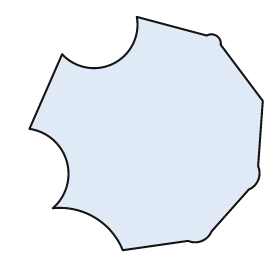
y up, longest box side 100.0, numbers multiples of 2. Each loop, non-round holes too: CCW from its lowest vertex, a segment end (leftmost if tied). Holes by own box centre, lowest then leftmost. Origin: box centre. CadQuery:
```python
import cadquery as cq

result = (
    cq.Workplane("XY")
    .moveTo(-10.0, -50.0)
    .lineTo(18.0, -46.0)
    .threePointArc((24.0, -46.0), (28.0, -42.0))
    .lineTo(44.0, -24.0)
    .threePointArc((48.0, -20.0), (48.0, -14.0))
    .lineTo(50.0, 14.0)
    .lineTo(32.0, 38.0)
    .threePointArc((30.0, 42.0), (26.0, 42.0))
    .lineTo(-4.0, 50.0)
    .threePointArc((-14.0, 30.0), (-36.0, 34.0))
    .lineTo(-50.0, 2.0)
    .threePointArc((-34.0, -12.0), (-40.0, -32.0))
    .threePointArc((-22.0, -36.0), (-10.0, -50.0))
    .close()
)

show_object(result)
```